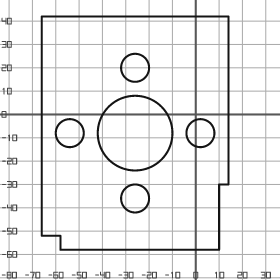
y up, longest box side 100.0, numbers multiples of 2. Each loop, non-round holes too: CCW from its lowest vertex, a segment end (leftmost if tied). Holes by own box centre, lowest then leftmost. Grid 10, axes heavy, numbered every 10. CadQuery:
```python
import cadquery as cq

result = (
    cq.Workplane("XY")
    .moveTo(-58.0, -58.0)
    .lineTo(10.0, -58.0)
    .lineTo(10.0, -30.0)
    .lineTo(14.0, -30.0)
    .lineTo(14.0, 42.0)
    .lineTo(-66.0, 42.0)
    .lineTo(-66.0, -52.0)
    .lineTo(-58.0, -52.0)
    .close()
    .moveTo(-26.0, -36.0)
    .circle(6.0)
    .moveTo(-54.0, -8.0)
    .circle(6.0)
    .moveTo(-26.0, -8.0)
    .circle(16.0)
    .moveTo(2.0, -8.0)
    .circle(6.0)
    .moveTo(-26.0, 20.0)
    .circle(6.0)
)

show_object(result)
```